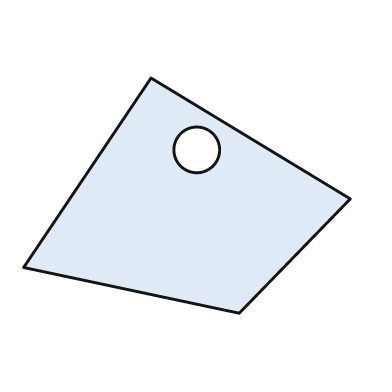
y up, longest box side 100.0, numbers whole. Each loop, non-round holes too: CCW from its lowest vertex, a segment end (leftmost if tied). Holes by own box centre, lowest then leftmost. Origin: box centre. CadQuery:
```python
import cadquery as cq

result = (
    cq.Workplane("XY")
    .moveTo(16.0, -36.0)
    .lineTo(50.0, -1.0)
    .lineTo(-11.0, 36.0)
    .lineTo(-50.0, -22.0)
    .close()
    .moveTo(3.0, 14.0)
    .circle(7.0)
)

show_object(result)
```